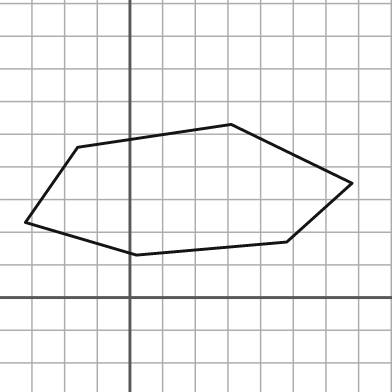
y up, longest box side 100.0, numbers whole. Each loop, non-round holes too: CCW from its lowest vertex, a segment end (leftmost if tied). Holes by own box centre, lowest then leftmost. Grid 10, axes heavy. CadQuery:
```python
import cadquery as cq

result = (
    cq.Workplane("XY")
    .moveTo(2.0, 13.0)
    .lineTo(48.0, 17.0)
    .lineTo(68.0, 35.0)
    .lineTo(31.0, 53.0)
    .lineTo(-16.0, 46.0)
    .lineTo(-32.0, 23.0)
    .close()
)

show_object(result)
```